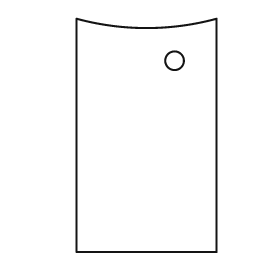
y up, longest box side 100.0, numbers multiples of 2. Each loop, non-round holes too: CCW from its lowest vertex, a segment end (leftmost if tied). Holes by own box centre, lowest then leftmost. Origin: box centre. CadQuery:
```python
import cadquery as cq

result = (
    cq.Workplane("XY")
    .moveTo(-30.0, -50.0)
    .lineTo(30.0, -50.0)
    .lineTo(30.0, 50.0)
    .threePointArc((0.0, 46.0), (-30.0, 50.0))
    .close()
    .moveTo(12.0, 32.0)
    .circle(4.0)
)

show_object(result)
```